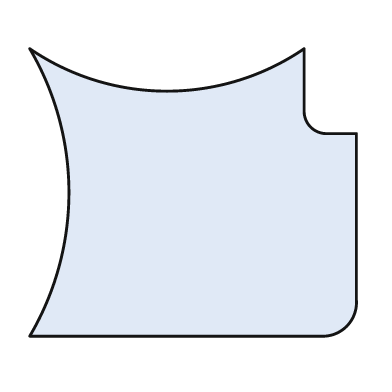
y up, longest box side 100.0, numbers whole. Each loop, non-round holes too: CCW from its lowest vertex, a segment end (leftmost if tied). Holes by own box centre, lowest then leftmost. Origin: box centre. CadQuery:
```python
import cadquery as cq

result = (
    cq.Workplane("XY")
    .moveTo(-50.0, -44.0)
    .lineTo(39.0, -44.0)
    .threePointArc((47.0, -41.0), (50.0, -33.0))
    .lineTo(50.0, 18.0)
    .lineTo(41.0, 18.0)
    .threePointArc((36.0, 20.0), (34.0, 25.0))
    .lineTo(34.0, 44.0)
    .threePointArc((-8.0, 31.0), (-50.0, 44.0))
    .threePointArc((-38.0, 0.0), (-50.0, -44.0))
    .close()
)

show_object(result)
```